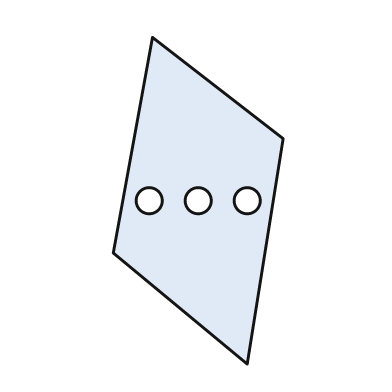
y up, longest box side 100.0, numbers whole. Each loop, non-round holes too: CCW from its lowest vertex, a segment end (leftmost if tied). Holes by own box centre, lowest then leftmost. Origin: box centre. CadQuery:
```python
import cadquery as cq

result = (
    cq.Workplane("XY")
    .moveTo(15.0, -50.0)
    .lineTo(26.0, 19.0)
    .lineTo(-14.0, 50.0)
    .lineTo(-26.0, -16.0)
    .close()
    .moveTo(-15.0, 0.0)
    .circle(4.0)
    .moveTo(0.0, 0.0)
    .circle(4.0)
    .moveTo(15.0, 0.0)
    .circle(4.0)
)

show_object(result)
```